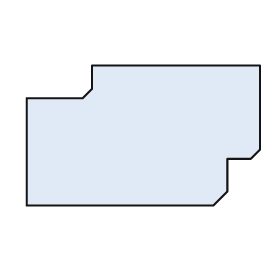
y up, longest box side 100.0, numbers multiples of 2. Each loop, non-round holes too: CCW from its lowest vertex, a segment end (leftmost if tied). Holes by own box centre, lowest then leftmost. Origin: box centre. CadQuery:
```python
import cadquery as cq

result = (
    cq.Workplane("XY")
    .moveTo(-50.0, -30.0)
    .lineTo(30.0, -30.0)
    .lineTo(36.0, -24.0)
    .lineTo(36.0, -10.0)
    .lineTo(46.0, -10.0)
    .lineTo(50.0, -6.0)
    .lineTo(50.0, 30.0)
    .lineTo(-22.0, 30.0)
    .lineTo(-22.0, 20.0)
    .lineTo(-26.0, 16.0)
    .lineTo(-50.0, 16.0)
    .close()
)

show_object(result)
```